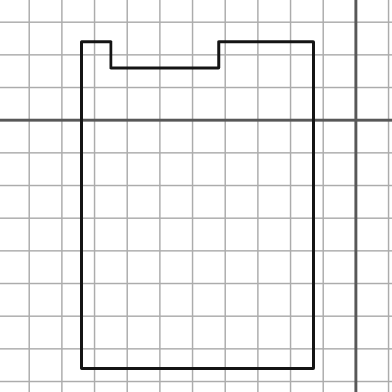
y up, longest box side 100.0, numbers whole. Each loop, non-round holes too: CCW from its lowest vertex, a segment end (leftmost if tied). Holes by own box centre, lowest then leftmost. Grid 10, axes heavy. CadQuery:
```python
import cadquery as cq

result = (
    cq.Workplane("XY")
    .moveTo(-84.0, -76.0)
    .lineTo(-13.0, -76.0)
    .lineTo(-13.0, 24.0)
    .lineTo(-42.0, 24.0)
    .lineTo(-42.0, 16.0)
    .lineTo(-75.0, 16.0)
    .lineTo(-75.0, 24.0)
    .lineTo(-84.0, 24.0)
    .close()
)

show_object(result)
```